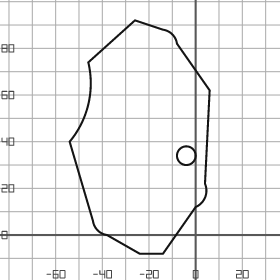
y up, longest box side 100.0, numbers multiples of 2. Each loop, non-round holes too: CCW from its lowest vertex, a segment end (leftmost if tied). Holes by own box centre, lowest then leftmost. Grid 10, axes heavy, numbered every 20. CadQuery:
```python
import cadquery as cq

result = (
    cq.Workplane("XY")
    .moveTo(-24.0, -8.0)
    .lineTo(-14.0, -8.0)
    .lineTo(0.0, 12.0)
    .threePointArc((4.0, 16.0), (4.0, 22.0))
    .lineTo(6.0, 62.0)
    .lineTo(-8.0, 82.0)
    .threePointArc((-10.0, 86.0), (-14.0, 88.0))
    .lineTo(-26.0, 92.0)
    .lineTo(-46.0, 74.0)
    .threePointArc((-46.0, 56.0), (-54.0, 40.0))
    .lineTo(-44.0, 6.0)
    .threePointArc((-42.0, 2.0), (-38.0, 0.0))
    .close()
    .moveTo(-4.0, 34.0)
    .circle(4.0)
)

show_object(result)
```